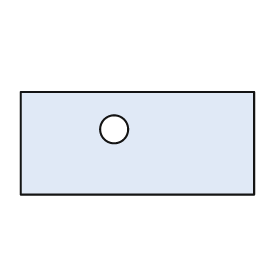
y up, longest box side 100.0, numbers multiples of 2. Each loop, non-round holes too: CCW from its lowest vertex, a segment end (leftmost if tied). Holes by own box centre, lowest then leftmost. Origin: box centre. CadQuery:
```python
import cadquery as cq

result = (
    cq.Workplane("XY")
    .moveTo(-50.0, -22.0)
    .lineTo(50.0, -22.0)
    .lineTo(50.0, 22.0)
    .lineTo(-50.0, 22.0)
    .close()
    .moveTo(-10.0, 6.0)
    .circle(6.0)
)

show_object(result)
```